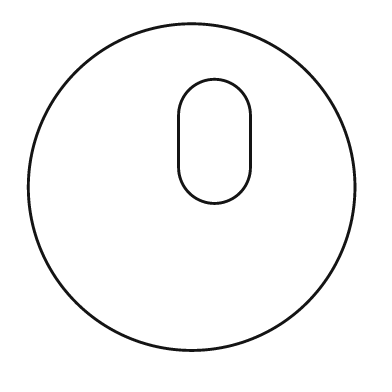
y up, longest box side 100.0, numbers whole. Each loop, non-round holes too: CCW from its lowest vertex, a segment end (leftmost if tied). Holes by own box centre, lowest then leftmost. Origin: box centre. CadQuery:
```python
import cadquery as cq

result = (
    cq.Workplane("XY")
    .moveTo(0.0, 0.0)
    .circle(50.0)
    .moveTo(-4.0, 6.0)
    .threePointArc((7.0, -5.0), (18.0, 6.0))
    .lineTo(18.0, 22.0)
    .threePointArc((7.0, 33.0), (-4.0, 22.0))
    .close()
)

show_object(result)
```